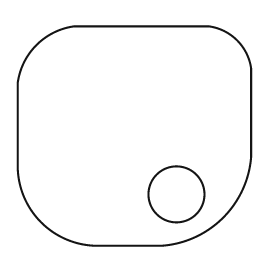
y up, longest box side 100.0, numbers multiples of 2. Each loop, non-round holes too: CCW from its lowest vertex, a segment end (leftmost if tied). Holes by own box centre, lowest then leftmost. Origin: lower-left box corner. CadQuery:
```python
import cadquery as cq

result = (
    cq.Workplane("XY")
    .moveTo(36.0, 0.0)
    .lineTo(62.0, 0.0)
    .threePointArc((88.0, 12.0), (100.0, 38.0))
    .lineTo(100.0, 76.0)
    .threePointArc((94.0, 88.0), (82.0, 94.0))
    .lineTo(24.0, 94.0)
    .threePointArc((8.0, 86.0), (0.0, 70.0))
    .lineTo(0.0, 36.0)
    .threePointArc((10.0, 10.0), (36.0, 0.0))
    .close()
    .moveTo(68.0, 22.0)
    .circle(12.0)
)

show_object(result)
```